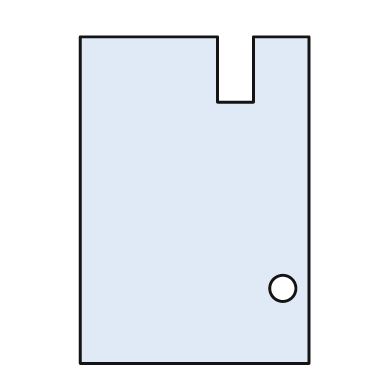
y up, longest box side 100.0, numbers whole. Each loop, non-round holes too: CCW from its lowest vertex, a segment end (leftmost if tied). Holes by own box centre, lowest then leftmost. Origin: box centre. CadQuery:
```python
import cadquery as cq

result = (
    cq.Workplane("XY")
    .moveTo(-35.0, -50.0)
    .lineTo(35.0, -50.0)
    .lineTo(35.0, 50.0)
    .lineTo(18.0, 50.0)
    .lineTo(18.0, 30.0)
    .lineTo(7.0, 30.0)
    .lineTo(7.0, 50.0)
    .lineTo(-35.0, 50.0)
    .close()
    .moveTo(27.0, -27.0)
    .circle(4.0)
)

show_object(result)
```